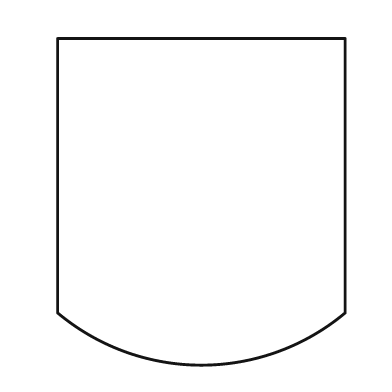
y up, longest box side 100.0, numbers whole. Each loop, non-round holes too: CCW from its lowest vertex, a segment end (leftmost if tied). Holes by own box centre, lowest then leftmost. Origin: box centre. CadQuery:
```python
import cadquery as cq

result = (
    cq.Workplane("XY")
    .moveTo(-44.0, -34.0)
    .threePointArc((0.0, -50.0), (44.0, -34.0))
    .lineTo(44.0, 50.0)
    .lineTo(-44.0, 50.0)
    .close()
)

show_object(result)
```